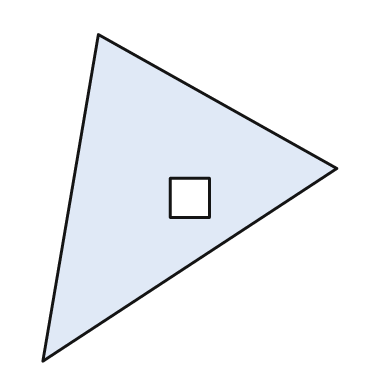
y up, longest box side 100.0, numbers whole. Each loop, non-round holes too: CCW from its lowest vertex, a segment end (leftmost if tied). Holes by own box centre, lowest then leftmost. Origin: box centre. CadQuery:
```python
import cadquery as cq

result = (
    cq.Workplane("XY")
    .moveTo(-45.0, -50.0)
    .lineTo(45.0, 9.0)
    .lineTo(-28.0, 50.0)
    .close()
    .moveTo(-6.0, -6.0)
    .lineTo(6.0, -6.0)
    .lineTo(6.0, 6.0)
    .lineTo(-6.0, 6.0)
    .close()
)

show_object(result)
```